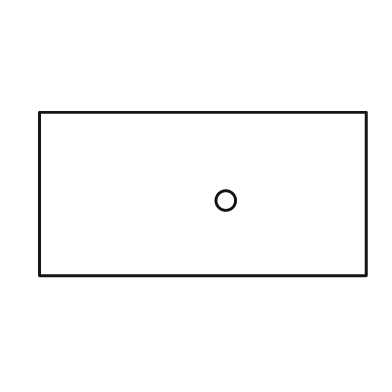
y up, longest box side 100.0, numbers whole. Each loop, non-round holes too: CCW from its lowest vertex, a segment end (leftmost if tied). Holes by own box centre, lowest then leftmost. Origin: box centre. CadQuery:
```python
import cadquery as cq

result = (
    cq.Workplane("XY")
    .moveTo(-50.0, -25.0)
    .lineTo(50.0, -25.0)
    .lineTo(50.0, 25.0)
    .lineTo(-50.0, 25.0)
    .close()
    .moveTo(7.0, -2.0)
    .circle(3.0)
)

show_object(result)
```